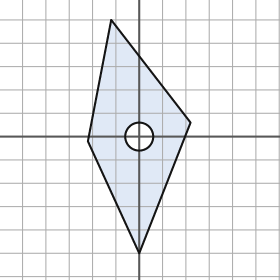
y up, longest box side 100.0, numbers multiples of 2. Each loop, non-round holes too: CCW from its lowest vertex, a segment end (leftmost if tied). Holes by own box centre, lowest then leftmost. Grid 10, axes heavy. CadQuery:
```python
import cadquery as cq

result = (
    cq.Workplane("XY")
    .moveTo(0.0, -50.0)
    .lineTo(22.0, 6.0)
    .lineTo(-12.0, 50.0)
    .lineTo(-22.0, -2.0)
    .close()
    .moveTo(0.0, 0.0)
    .circle(6.0)
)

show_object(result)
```